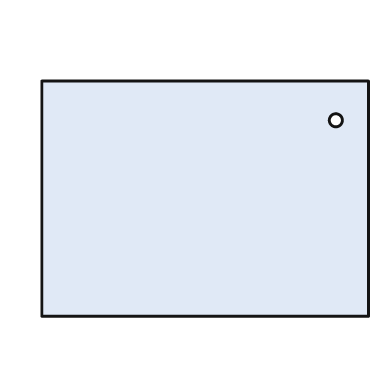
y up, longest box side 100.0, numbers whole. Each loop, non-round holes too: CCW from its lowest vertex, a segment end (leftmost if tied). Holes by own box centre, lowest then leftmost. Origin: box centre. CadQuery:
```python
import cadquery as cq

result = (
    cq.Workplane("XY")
    .moveTo(-50.0, -36.0)
    .lineTo(50.0, -36.0)
    .lineTo(50.0, 36.0)
    .lineTo(-50.0, 36.0)
    .close()
    .moveTo(40.0, 24.0)
    .circle(2.0)
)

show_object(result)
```